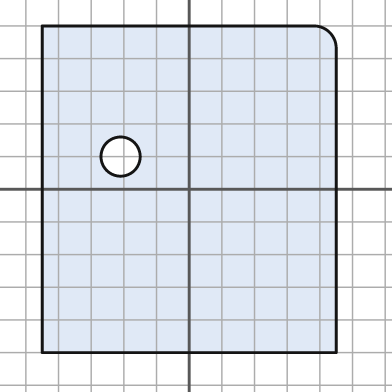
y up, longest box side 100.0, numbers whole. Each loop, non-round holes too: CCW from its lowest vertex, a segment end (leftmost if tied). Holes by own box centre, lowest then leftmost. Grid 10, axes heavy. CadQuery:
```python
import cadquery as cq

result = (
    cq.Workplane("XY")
    .moveTo(-45.0, -50.0)
    .lineTo(45.0, -50.0)
    .lineTo(45.0, 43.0)
    .threePointArc((43.0, 48.0), (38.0, 50.0))
    .lineTo(-45.0, 50.0)
    .close()
    .moveTo(-21.0, 10.0)
    .circle(6.0)
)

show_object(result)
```